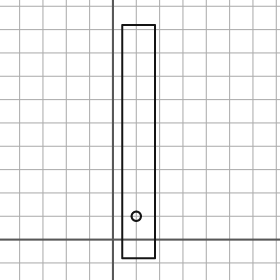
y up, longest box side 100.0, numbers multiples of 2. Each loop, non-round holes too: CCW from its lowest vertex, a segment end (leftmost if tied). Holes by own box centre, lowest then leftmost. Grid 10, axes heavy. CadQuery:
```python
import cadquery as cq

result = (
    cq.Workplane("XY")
    .moveTo(4.0, -8.0)
    .lineTo(18.0, -8.0)
    .lineTo(18.0, 92.0)
    .lineTo(4.0, 92.0)
    .close()
    .moveTo(10.0, 10.0)
    .circle(2.0)
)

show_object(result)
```